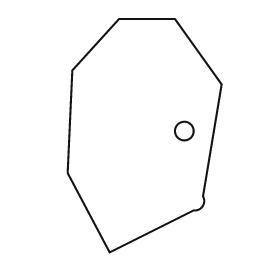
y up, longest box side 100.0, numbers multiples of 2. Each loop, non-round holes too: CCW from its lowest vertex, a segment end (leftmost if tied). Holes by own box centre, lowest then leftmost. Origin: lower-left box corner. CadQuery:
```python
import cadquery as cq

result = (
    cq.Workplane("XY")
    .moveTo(18.0, 0.0)
    .lineTo(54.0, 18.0)
    .threePointArc((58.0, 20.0), (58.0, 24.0))
    .lineTo(66.0, 72.0)
    .lineTo(46.0, 100.0)
    .lineTo(22.0, 100.0)
    .lineTo(2.0, 78.0)
    .lineTo(0.0, 34.0)
    .close()
    .moveTo(50.0, 52.0)
    .circle(4.0)
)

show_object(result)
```